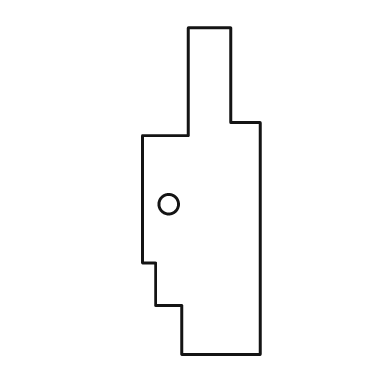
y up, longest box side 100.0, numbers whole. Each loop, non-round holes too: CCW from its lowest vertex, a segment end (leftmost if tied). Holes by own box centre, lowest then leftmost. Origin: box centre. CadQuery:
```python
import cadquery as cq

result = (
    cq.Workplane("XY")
    .moveTo(-6.0, -50.0)
    .lineTo(18.0, -50.0)
    .lineTo(18.0, 21.0)
    .lineTo(9.0, 21.0)
    .lineTo(9.0, 50.0)
    .lineTo(-4.0, 50.0)
    .lineTo(-4.0, 17.0)
    .lineTo(-18.0, 17.0)
    .lineTo(-18.0, -22.0)
    .lineTo(-14.0, -22.0)
    .lineTo(-14.0, -35.0)
    .lineTo(-6.0, -35.0)
    .close()
    .moveTo(-10.0, -4.0)
    .circle(3.0)
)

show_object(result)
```